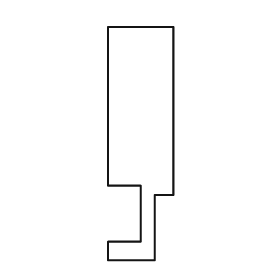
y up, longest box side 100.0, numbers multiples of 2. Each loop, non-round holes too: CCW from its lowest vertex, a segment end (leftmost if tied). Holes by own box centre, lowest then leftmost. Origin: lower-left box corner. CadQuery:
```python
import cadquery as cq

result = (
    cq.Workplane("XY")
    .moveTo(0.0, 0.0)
    .lineTo(20.0, 0.0)
    .lineTo(20.0, 28.0)
    .lineTo(28.0, 28.0)
    .lineTo(28.0, 100.0)
    .lineTo(0.0, 100.0)
    .lineTo(0.0, 32.0)
    .lineTo(14.0, 32.0)
    .lineTo(14.0, 8.0)
    .lineTo(0.0, 8.0)
    .close()
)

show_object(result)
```